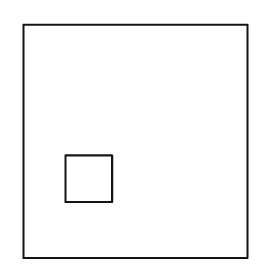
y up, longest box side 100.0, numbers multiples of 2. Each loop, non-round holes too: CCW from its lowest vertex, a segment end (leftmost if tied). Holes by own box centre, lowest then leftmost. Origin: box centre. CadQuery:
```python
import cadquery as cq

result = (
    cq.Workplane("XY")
    .moveTo(-48.0, -50.0)
    .lineTo(48.0, -50.0)
    .lineTo(48.0, 50.0)
    .lineTo(-48.0, 50.0)
    .close()
    .moveTo(-30.0, -26.0)
    .lineTo(-10.0, -26.0)
    .lineTo(-10.0, -6.0)
    .lineTo(-30.0, -6.0)
    .close()
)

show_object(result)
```